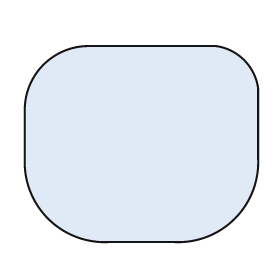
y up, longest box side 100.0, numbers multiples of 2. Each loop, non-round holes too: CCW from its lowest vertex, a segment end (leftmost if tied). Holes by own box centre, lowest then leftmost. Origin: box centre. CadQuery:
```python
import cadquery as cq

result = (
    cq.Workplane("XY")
    .moveTo(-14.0, -42.0)
    .lineTo(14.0, -42.0)
    .threePointArc((40.0, -32.0), (50.0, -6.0))
    .lineTo(50.0, 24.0)
    .threePointArc((44.0, 36.0), (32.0, 42.0))
    .lineTo(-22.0, 42.0)
    .threePointArc((-42.0, 34.0), (-50.0, 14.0))
    .lineTo(-50.0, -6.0)
    .threePointArc((-40.0, -32.0), (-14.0, -42.0))
    .close()
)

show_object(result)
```